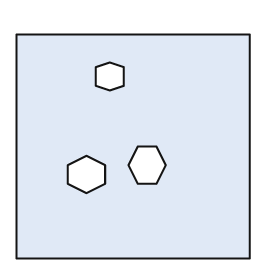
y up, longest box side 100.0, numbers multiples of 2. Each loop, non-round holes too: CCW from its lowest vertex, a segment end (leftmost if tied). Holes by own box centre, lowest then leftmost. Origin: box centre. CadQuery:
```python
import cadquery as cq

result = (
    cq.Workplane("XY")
    .moveTo(-50.0, -48.0)
    .lineTo(50.0, -48.0)
    .lineTo(50.0, 48.0)
    .lineTo(-50.0, 48.0)
    .close()
    .moveTo(-20.0, -20.0)
    .lineTo(-12.0, -16.0)
    .lineTo(-12.0, -8.0)
    .lineTo(-20.0, -4.0)
    .lineTo(-28.0, -8.0)
    .lineTo(-28.0, -16.0)
    .close()
    .moveTo(2.0, -16.0)
    .lineTo(10.0, -16.0)
    .lineTo(14.0, -8.0)
    .lineTo(10.0, 0.0)
    .lineTo(2.0, 0.0)
    .lineTo(-2.0, -8.0)
    .close()
    .moveTo(-10.0, 24.0)
    .lineTo(-4.0, 26.0)
    .lineTo(-4.0, 34.0)
    .lineTo(-10.0, 36.0)
    .lineTo(-16.0, 34.0)
    .lineTo(-16.0, 26.0)
    .close()
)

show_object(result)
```